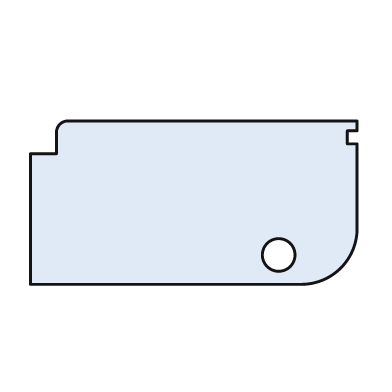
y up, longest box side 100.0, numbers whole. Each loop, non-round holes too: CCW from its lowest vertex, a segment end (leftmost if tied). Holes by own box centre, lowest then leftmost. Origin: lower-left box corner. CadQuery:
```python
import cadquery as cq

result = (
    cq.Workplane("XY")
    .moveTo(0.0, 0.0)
    .lineTo(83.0, 0.0)
    .threePointArc((95.0, 5.0), (100.0, 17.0))
    .lineTo(100.0, 43.0)
    .lineTo(97.0, 43.0)
    .lineTo(97.0, 47.0)
    .lineTo(100.0, 47.0)
    .lineTo(100.0, 50.0)
    .lineTo(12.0, 50.0)
    .threePointArc((9.0, 49.0), (8.0, 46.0))
    .lineTo(8.0, 40.0)
    .lineTo(0.0, 40.0)
    .close()
    .moveTo(76.0, 9.0)
    .circle(5.0)
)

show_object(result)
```